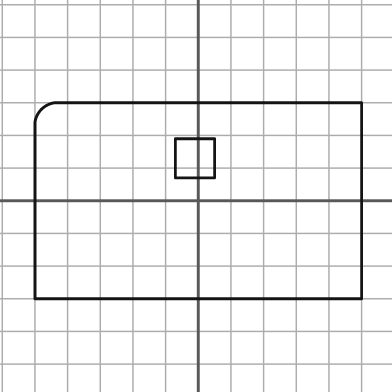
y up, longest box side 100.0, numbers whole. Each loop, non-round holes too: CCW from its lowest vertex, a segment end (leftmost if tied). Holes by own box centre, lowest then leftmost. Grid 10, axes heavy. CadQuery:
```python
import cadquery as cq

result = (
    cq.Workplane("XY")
    .moveTo(-50.0, -30.0)
    .lineTo(50.0, -30.0)
    .lineTo(50.0, 30.0)
    .lineTo(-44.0, 30.0)
    .threePointArc((-48.0, 28.0), (-50.0, 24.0))
    .close()
    .moveTo(-7.0, 7.0)
    .lineTo(5.0, 7.0)
    .lineTo(5.0, 19.0)
    .lineTo(-7.0, 19.0)
    .close()
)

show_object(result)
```